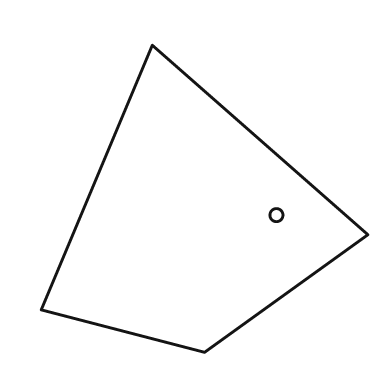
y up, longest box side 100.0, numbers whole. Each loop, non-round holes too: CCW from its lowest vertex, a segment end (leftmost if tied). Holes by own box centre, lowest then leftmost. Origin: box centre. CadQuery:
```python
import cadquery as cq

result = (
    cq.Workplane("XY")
    .moveTo(0.0, -47.0)
    .lineTo(50.0, -11.0)
    .lineTo(-16.0, 47.0)
    .lineTo(-50.0, -34.0)
    .close()
    .moveTo(22.0, -5.0)
    .circle(2.0)
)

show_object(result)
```